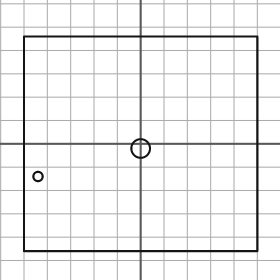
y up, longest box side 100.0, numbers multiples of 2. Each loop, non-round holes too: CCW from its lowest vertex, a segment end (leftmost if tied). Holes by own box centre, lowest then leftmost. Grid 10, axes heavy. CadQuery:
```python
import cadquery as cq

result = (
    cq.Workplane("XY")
    .moveTo(-50.0, -46.0)
    .lineTo(50.0, -46.0)
    .lineTo(50.0, 46.0)
    .lineTo(-50.0, 46.0)
    .close()
    .moveTo(-44.0, -14.0)
    .circle(2.0)
    .moveTo(0.0, -2.0)
    .circle(4.0)
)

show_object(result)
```